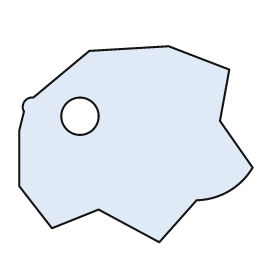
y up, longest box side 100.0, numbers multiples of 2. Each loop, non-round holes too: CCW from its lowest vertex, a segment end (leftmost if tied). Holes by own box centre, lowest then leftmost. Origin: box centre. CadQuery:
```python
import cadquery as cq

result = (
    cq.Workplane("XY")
    .moveTo(10.0, -42.0)
    .lineTo(26.0, -24.0)
    .threePointArc((40.0, -20.0), (50.0, -10.0))
    .lineTo(36.0, 10.0)
    .lineTo(40.0, 32.0)
    .lineTo(14.0, 42.0)
    .lineTo(-20.0, 40.0)
    .lineTo(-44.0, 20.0)
    .threePointArc((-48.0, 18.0), (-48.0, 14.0))
    .lineTo(-50.0, 6.0)
    .lineTo(-50.0, -18.0)
    .lineTo(-36.0, -36.0)
    .lineTo(-16.0, -28.0)
    .close()
    .moveTo(-24.0, 12.0)
    .circle(8.0)
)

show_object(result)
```